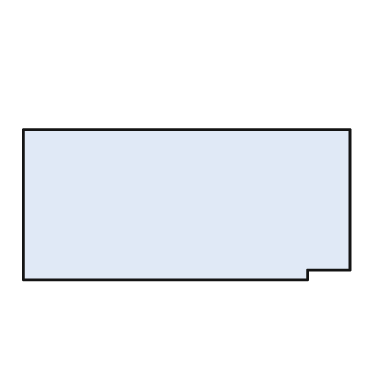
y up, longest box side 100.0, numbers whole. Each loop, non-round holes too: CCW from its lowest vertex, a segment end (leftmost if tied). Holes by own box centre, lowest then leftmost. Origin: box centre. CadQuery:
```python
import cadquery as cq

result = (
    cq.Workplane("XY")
    .moveTo(-50.0, -23.0)
    .lineTo(37.0, -23.0)
    .lineTo(37.0, -20.0)
    .lineTo(50.0, -20.0)
    .lineTo(50.0, 23.0)
    .lineTo(-50.0, 23.0)
    .close()
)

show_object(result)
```